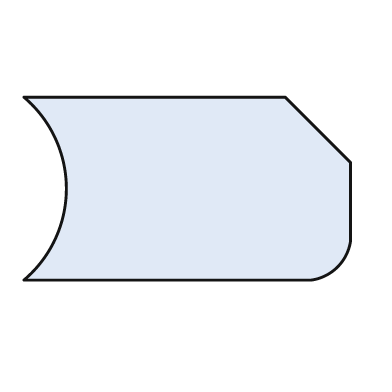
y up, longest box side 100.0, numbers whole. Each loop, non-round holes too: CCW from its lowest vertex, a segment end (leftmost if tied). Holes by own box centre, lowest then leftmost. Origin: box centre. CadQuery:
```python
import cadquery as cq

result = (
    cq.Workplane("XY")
    .moveTo(-50.0, -28.0)
    .lineTo(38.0, -28.0)
    .threePointArc((46.0, -24.0), (50.0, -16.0))
    .lineTo(50.0, 8.0)
    .lineTo(30.0, 28.0)
    .lineTo(-50.0, 28.0)
    .threePointArc((-37.0, 0.0), (-50.0, -28.0))
    .close()
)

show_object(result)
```